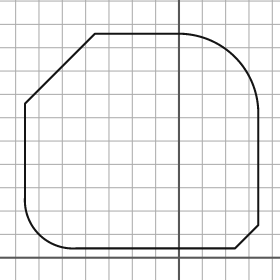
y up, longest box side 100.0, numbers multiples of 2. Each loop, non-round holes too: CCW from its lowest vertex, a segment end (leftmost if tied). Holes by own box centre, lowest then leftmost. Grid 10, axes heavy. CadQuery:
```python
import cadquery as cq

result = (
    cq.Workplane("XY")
    .moveTo(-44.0, 4.0)
    .lineTo(24.0, 4.0)
    .lineTo(34.0, 14.0)
    .lineTo(34.0, 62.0)
    .threePointArc((24.0, 86.0), (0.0, 96.0))
    .lineTo(-36.0, 96.0)
    .lineTo(-66.0, 66.0)
    .lineTo(-66.0, 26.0)
    .threePointArc((-60.0, 10.0), (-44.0, 4.0))
    .close()
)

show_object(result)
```